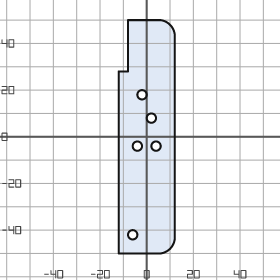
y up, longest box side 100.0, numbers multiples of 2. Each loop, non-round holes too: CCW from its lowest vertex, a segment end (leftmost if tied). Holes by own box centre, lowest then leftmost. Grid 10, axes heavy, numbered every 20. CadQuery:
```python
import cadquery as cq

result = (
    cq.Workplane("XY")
    .moveTo(-12.0, -50.0)
    .lineTo(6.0, -50.0)
    .threePointArc((10.0, -48.0), (12.0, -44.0))
    .lineTo(12.0, 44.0)
    .threePointArc((10.0, 48.0), (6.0, 50.0))
    .lineTo(-8.0, 50.0)
    .lineTo(-8.0, 28.0)
    .lineTo(-12.0, 28.0)
    .close()
    .moveTo(-6.0, -42.0)
    .circle(2.0)
    .moveTo(-4.0, -4.0)
    .circle(2.0)
    .moveTo(4.0, -4.0)
    .circle(2.0)
    .moveTo(2.0, 8.0)
    .circle(2.0)
    .moveTo(-2.0, 18.0)
    .circle(2.0)
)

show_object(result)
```